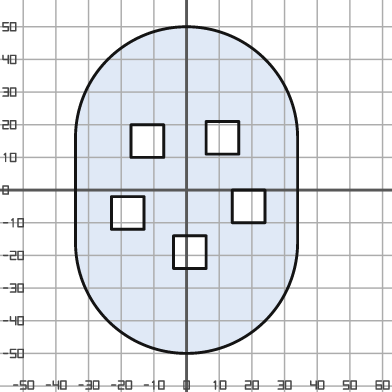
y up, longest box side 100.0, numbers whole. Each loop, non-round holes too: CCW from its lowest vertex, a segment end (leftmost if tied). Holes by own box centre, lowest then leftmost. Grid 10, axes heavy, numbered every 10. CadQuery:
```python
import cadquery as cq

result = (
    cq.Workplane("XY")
    .moveTo(-34.0, -16.0)
    .threePointArc((0.0, -50.0), (34.0, -16.0))
    .lineTo(34.0, 16.0)
    .threePointArc((0.0, 50.0), (-34.0, 16.0))
    .close()
    .moveTo(-4.0, -24.0)
    .lineTo(6.0, -24.0)
    .lineTo(6.0, -14.0)
    .lineTo(-4.0, -14.0)
    .close()
    .moveTo(-23.0, -12.0)
    .lineTo(-13.0, -12.0)
    .lineTo(-13.0, -2.0)
    .lineTo(-23.0, -2.0)
    .close()
    .moveTo(14.0, -10.0)
    .lineTo(24.0, -10.0)
    .lineTo(24.0, 0.0)
    .lineTo(14.0, 0.0)
    .close()
    .moveTo(-17.0, 10.0)
    .lineTo(-7.0, 10.0)
    .lineTo(-7.0, 20.0)
    .lineTo(-17.0, 20.0)
    .close()
    .moveTo(6.0, 11.0)
    .lineTo(16.0, 11.0)
    .lineTo(16.0, 21.0)
    .lineTo(6.0, 21.0)
    .close()
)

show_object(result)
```